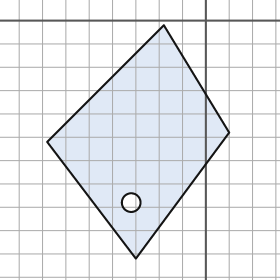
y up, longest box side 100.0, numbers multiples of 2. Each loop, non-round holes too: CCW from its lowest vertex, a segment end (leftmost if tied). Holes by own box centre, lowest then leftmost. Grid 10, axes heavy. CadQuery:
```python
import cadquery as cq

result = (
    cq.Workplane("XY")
    .moveTo(-30.0, -102.0)
    .lineTo(10.0, -48.0)
    .lineTo(-18.0, -2.0)
    .lineTo(-68.0, -52.0)
    .close()
    .moveTo(-32.0, -78.0)
    .circle(4.0)
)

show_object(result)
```